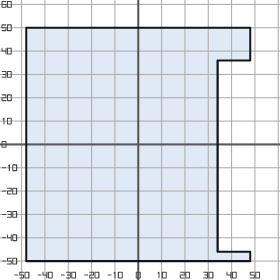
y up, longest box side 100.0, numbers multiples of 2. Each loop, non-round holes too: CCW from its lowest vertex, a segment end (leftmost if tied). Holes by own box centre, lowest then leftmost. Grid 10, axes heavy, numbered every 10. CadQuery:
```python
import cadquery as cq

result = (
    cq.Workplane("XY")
    .moveTo(-48.0, -50.0)
    .lineTo(48.0, -50.0)
    .lineTo(48.0, -46.0)
    .lineTo(34.0, -46.0)
    .lineTo(34.0, 36.0)
    .lineTo(48.0, 36.0)
    .lineTo(48.0, 50.0)
    .lineTo(-48.0, 50.0)
    .close()
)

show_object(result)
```